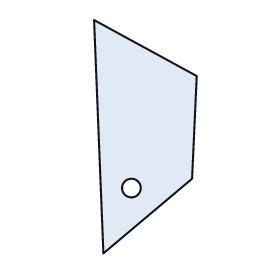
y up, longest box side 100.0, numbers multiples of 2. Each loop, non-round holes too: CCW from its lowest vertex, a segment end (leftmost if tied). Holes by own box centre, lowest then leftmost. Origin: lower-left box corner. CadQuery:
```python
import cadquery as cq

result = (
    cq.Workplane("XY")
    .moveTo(4.0, 0.0)
    .lineTo(42.0, 32.0)
    .lineTo(44.0, 76.0)
    .lineTo(0.0, 100.0)
    .close()
    .moveTo(16.0, 28.0)
    .circle(4.0)
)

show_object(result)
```